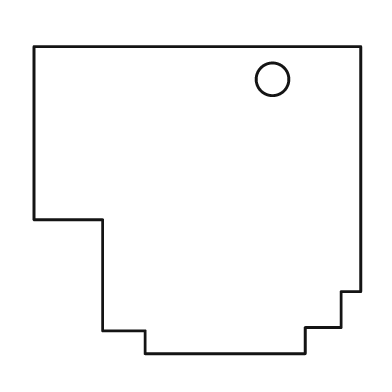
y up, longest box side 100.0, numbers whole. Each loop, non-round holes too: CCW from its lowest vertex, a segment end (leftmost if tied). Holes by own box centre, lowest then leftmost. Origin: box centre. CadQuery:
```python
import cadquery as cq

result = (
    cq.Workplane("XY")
    .moveTo(-16.0, -47.0)
    .lineTo(33.0, -47.0)
    .lineTo(33.0, -39.0)
    .lineTo(44.0, -39.0)
    .lineTo(44.0, -28.0)
    .lineTo(50.0, -28.0)
    .lineTo(50.0, 47.0)
    .lineTo(-50.0, 47.0)
    .lineTo(-50.0, -6.0)
    .lineTo(-29.0, -6.0)
    .lineTo(-29.0, -40.0)
    .lineTo(-16.0, -40.0)
    .close()
    .moveTo(23.0, 37.0)
    .circle(5.0)
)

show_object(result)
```